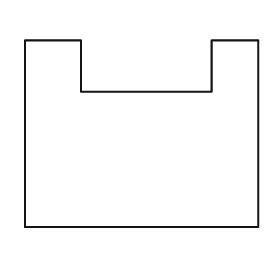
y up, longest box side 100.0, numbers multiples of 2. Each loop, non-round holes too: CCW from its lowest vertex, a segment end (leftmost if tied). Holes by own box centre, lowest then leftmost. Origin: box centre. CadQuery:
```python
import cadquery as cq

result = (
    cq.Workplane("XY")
    .moveTo(-50.0, -40.0)
    .lineTo(50.0, -40.0)
    .lineTo(50.0, 40.0)
    .lineTo(30.0, 40.0)
    .lineTo(30.0, 18.0)
    .lineTo(-26.0, 18.0)
    .lineTo(-26.0, 40.0)
    .lineTo(-50.0, 40.0)
    .close()
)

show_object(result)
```